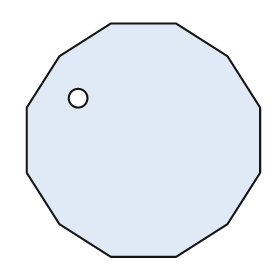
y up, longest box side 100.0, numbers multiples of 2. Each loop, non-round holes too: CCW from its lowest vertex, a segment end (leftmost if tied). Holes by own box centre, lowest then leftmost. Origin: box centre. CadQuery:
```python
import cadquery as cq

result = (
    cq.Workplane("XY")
    .moveTo(-14.0, -50.0)
    .lineTo(14.0, -50.0)
    .lineTo(36.0, -36.0)
    .lineTo(50.0, -14.0)
    .lineTo(50.0, 14.0)
    .lineTo(36.0, 36.0)
    .lineTo(14.0, 50.0)
    .lineTo(-14.0, 50.0)
    .lineTo(-36.0, 36.0)
    .lineTo(-50.0, 14.0)
    .lineTo(-50.0, -14.0)
    .lineTo(-36.0, -36.0)
    .close()
    .moveTo(-28.0, 18.0)
    .circle(4.0)
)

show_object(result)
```